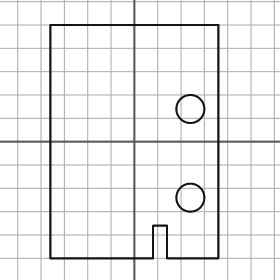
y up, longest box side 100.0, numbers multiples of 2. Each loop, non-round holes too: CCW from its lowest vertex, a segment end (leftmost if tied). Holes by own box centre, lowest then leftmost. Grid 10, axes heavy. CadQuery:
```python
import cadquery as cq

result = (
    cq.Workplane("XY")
    .moveTo(-36.0, -50.0)
    .lineTo(8.0, -50.0)
    .lineTo(8.0, -36.0)
    .lineTo(14.0, -36.0)
    .lineTo(14.0, -50.0)
    .lineTo(36.0, -50.0)
    .lineTo(36.0, 50.0)
    .lineTo(-36.0, 50.0)
    .close()
    .moveTo(24.0, -24.0)
    .circle(6.0)
    .moveTo(24.0, 14.0)
    .circle(6.0)
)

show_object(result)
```